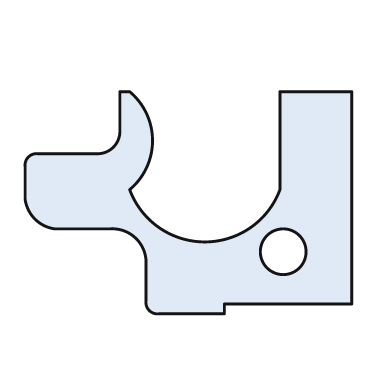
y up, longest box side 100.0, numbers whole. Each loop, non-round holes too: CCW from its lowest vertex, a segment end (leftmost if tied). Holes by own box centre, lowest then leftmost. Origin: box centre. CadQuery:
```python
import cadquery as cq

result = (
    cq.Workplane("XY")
    .moveTo(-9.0, -34.0)
    .lineTo(11.0, -34.0)
    .lineTo(11.0, -31.0)
    .lineTo(50.0, -31.0)
    .lineTo(50.0, 34.0)
    .lineTo(28.0, 34.0)
    .lineTo(28.0, 4.0)
    .threePointArc((5.0, -12.0), (-18.0, 4.0))
    .threePointArc((-11.0, 19.0), (-18.0, 34.0))
    .lineTo(-21.0, 34.0)
    .lineTo(-21.0, 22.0)
    .threePointArc((-23.0, 17.0), (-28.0, 15.0))
    .lineTo(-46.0, 15.0)
    .threePointArc((-49.0, 14.0), (-50.0, 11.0))
    .lineTo(-50.0, 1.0)
    .threePointArc((-47.0, -5.0), (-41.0, -8.0))
    .lineTo(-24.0, -8.0)
    .threePointArc((-16.0, -11.0), (-13.0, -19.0))
    .lineTo(-13.0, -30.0)
    .threePointArc((-12.0, -33.0), (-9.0, -34.0))
    .close()
    .moveTo(29.0, -15.0)
    .circle(7.0)
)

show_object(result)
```